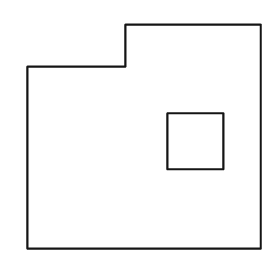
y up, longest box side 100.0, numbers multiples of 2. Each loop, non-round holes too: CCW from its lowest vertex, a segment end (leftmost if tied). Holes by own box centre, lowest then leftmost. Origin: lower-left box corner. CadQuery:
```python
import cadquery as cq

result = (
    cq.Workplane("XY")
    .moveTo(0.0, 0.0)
    .lineTo(100.0, 0.0)
    .lineTo(100.0, 96.0)
    .lineTo(42.0, 96.0)
    .lineTo(42.0, 78.0)
    .lineTo(0.0, 78.0)
    .close()
    .moveTo(60.0, 34.0)
    .lineTo(84.0, 34.0)
    .lineTo(84.0, 58.0)
    .lineTo(60.0, 58.0)
    .close()
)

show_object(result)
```